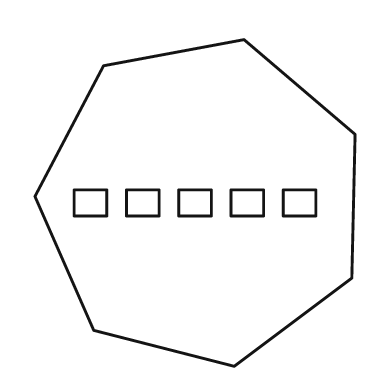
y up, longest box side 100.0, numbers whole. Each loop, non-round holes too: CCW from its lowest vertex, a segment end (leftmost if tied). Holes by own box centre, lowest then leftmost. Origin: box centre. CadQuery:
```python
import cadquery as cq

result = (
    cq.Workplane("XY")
    .moveTo(12.0, -50.0)
    .lineTo(48.0, -23.0)
    .lineTo(49.0, 21.0)
    .lineTo(15.0, 50.0)
    .lineTo(-28.0, 42.0)
    .lineTo(-49.0, 2.0)
    .lineTo(-31.0, -39.0)
    .close()
    .moveTo(-37.0, -4.0)
    .lineTo(-27.0, -4.0)
    .lineTo(-27.0, 4.0)
    .lineTo(-37.0, 4.0)
    .close()
    .moveTo(-21.0, -4.0)
    .lineTo(-11.0, -4.0)
    .lineTo(-11.0, 4.0)
    .lineTo(-21.0, 4.0)
    .close()
    .moveTo(-5.0, -4.0)
    .lineTo(5.0, -4.0)
    .lineTo(5.0, 4.0)
    .lineTo(-5.0, 4.0)
    .close()
    .moveTo(11.0, -4.0)
    .lineTo(21.0, -4.0)
    .lineTo(21.0, 4.0)
    .lineTo(11.0, 4.0)
    .close()
    .moveTo(27.0, -4.0)
    .lineTo(37.0, -4.0)
    .lineTo(37.0, 4.0)
    .lineTo(27.0, 4.0)
    .close()
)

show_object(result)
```